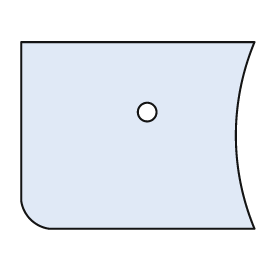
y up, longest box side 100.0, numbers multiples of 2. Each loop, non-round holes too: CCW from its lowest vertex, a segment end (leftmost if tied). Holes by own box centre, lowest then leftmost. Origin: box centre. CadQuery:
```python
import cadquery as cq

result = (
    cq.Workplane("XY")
    .moveTo(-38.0, -40.0)
    .lineTo(50.0, -40.0)
    .threePointArc((42.0, 0.0), (50.0, 40.0))
    .lineTo(-50.0, 40.0)
    .lineTo(-50.0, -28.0)
    .threePointArc((-46.0, -36.0), (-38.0, -40.0))
    .close()
    .moveTo(4.0, 10.0)
    .circle(4.0)
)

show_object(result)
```